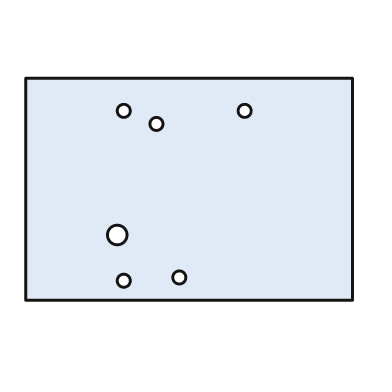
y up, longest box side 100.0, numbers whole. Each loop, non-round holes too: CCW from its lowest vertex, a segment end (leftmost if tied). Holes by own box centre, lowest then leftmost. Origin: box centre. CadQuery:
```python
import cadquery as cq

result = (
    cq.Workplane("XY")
    .moveTo(-50.0, -34.0)
    .lineTo(50.0, -34.0)
    .lineTo(50.0, 34.0)
    .lineTo(-50.0, 34.0)
    .close()
    .moveTo(-20.0, -28.0)
    .circle(2.0)
    .moveTo(-3.0, -27.0)
    .circle(2.0)
    .moveTo(-22.0, -14.0)
    .circle(3.0)
    .moveTo(-10.0, 20.0)
    .circle(2.0)
    .moveTo(-20.0, 24.0)
    .circle(2.0)
    .moveTo(17.0, 24.0)
    .circle(2.0)
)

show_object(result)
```